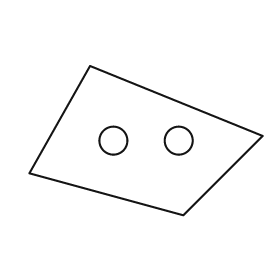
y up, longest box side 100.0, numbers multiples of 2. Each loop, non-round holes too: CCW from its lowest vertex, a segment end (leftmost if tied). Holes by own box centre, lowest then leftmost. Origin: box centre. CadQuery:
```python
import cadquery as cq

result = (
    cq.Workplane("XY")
    .moveTo(16.0, -32.0)
    .lineTo(50.0, 2.0)
    .lineTo(-24.0, 32.0)
    .lineTo(-50.0, -14.0)
    .close()
    .moveTo(-14.0, 0.0)
    .circle(6.0)
    .moveTo(14.0, 0.0)
    .circle(6.0)
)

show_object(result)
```